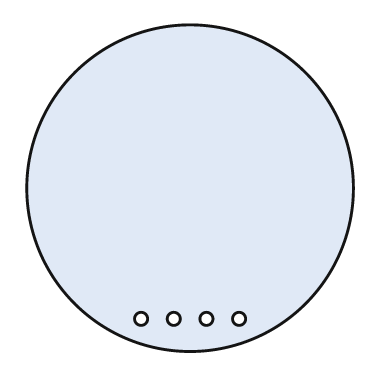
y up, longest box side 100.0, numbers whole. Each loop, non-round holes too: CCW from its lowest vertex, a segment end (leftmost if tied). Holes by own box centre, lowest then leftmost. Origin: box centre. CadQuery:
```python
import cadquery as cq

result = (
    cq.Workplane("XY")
    .moveTo(0.0, 0.0)
    .circle(50.0)
    .moveTo(-15.0, -40.0)
    .circle(2.0)
    .moveTo(-5.0, -40.0)
    .circle(2.0)
    .moveTo(5.0, -40.0)
    .circle(2.0)
    .moveTo(15.0, -40.0)
    .circle(2.0)
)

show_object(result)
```